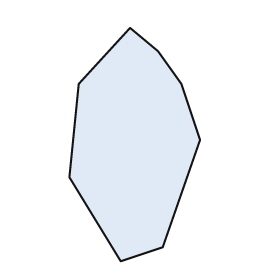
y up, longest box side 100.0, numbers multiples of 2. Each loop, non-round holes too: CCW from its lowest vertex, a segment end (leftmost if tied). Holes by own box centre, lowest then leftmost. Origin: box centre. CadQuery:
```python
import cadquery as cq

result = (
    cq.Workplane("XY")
    .moveTo(-6.0, -50.0)
    .lineTo(12.0, -44.0)
    .lineTo(28.0, 2.0)
    .lineTo(20.0, 26.0)
    .lineTo(10.0, 40.0)
    .lineTo(-2.0, 50.0)
    .lineTo(-24.0, 26.0)
    .lineTo(-28.0, -14.0)
    .close()
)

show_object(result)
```